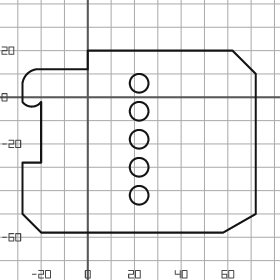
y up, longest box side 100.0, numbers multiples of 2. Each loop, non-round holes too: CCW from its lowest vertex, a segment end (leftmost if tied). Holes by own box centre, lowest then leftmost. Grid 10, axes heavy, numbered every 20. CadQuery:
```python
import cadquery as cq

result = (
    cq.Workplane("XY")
    .moveTo(-20.0, -58.0)
    .lineTo(58.0, -58.0)
    .lineTo(72.0, -50.0)
    .lineTo(72.0, 10.0)
    .lineTo(62.0, 20.0)
    .lineTo(0.0, 20.0)
    .lineTo(0.0, 12.0)
    .lineTo(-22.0, 12.0)
    .threePointArc((-26.0, 10.0), (-28.0, 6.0))
    .lineTo(-28.0, -2.0)
    .threePointArc((-24.0, -4.0), (-20.0, -2.0))
    .lineTo(-20.0, -28.0)
    .lineTo(-28.0, -28.0)
    .lineTo(-28.0, -50.0)
    .close()
    .moveTo(22.0, -42.0)
    .circle(4.0)
    .moveTo(22.0, -30.0)
    .circle(4.0)
    .moveTo(22.0, -18.0)
    .circle(4.0)
    .moveTo(22.0, -6.0)
    .circle(4.0)
    .moveTo(22.0, 6.0)
    .circle(4.0)
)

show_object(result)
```